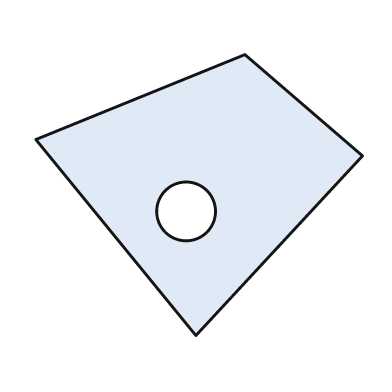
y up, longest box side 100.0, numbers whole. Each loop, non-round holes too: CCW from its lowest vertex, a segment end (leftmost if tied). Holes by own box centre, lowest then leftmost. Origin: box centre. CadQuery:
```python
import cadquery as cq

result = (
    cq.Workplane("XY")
    .moveTo(-1.0, -43.0)
    .lineTo(50.0, 12.0)
    .lineTo(14.0, 43.0)
    .lineTo(-50.0, 17.0)
    .close()
    .moveTo(-4.0, -5.0)
    .circle(9.0)
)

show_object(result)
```